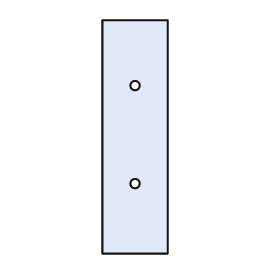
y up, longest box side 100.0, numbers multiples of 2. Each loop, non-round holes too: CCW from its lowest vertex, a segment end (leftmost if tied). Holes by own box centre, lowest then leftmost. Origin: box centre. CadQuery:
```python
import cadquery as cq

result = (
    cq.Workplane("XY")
    .moveTo(-14.0, -50.0)
    .lineTo(14.0, -50.0)
    .lineTo(14.0, 50.0)
    .lineTo(-14.0, 50.0)
    .close()
    .moveTo(0.0, -20.0)
    .circle(2.0)
    .moveTo(0.0, 22.0)
    .circle(2.0)
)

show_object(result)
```